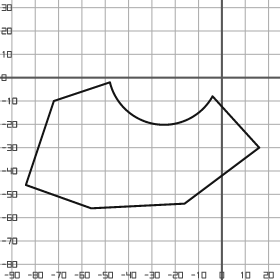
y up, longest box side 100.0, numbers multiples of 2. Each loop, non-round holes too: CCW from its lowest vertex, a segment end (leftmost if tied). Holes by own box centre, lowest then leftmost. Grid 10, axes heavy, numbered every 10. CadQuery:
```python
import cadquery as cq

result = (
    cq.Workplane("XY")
    .moveTo(-56.0, -56.0)
    .lineTo(-16.0, -54.0)
    .lineTo(16.0, -30.0)
    .lineTo(-4.0, -8.0)
    .threePointArc((-28.0, -20.0), (-48.0, -2.0))
    .lineTo(-72.0, -10.0)
    .lineTo(-84.0, -46.0)
    .close()
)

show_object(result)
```